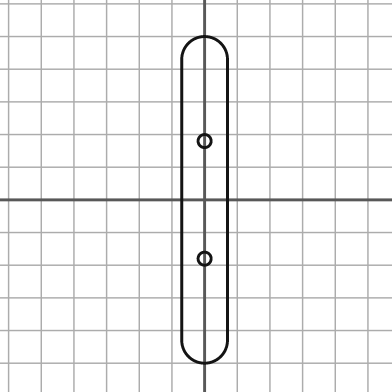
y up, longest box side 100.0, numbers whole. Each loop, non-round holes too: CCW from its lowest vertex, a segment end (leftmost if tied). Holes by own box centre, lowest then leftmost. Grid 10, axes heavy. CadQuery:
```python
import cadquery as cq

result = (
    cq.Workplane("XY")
    .moveTo(-7.0, -43.0)
    .threePointArc((0.0, -50.0), (7.0, -43.0))
    .lineTo(7.0, 43.0)
    .threePointArc((0.0, 50.0), (-7.0, 43.0))
    .close()
    .moveTo(0.0, -18.0)
    .circle(2.0)
    .moveTo(0.0, 18.0)
    .circle(2.0)
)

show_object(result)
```